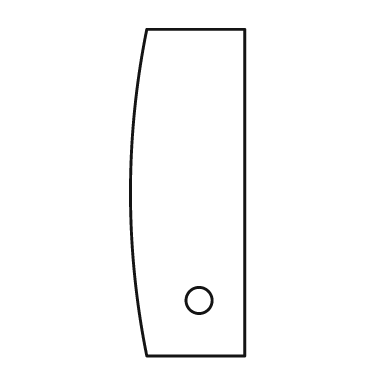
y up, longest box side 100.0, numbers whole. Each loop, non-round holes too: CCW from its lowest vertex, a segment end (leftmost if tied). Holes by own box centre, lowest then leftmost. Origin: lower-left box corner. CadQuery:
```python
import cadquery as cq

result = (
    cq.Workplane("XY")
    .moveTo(5.0, 0.0)
    .lineTo(35.0, 0.0)
    .lineTo(35.0, 100.0)
    .lineTo(5.0, 100.0)
    .threePointArc((0.0, 50.0), (5.0, 0.0))
    .close()
    .moveTo(21.0, 17.0)
    .circle(4.0)
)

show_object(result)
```